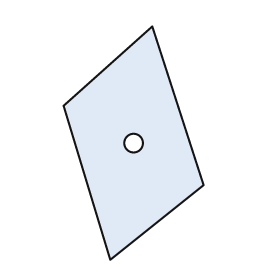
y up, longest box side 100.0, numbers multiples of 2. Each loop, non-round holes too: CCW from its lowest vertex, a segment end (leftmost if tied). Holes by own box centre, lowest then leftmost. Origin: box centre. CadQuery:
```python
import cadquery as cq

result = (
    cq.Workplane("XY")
    .moveTo(-10.0, -50.0)
    .lineTo(30.0, -18.0)
    .lineTo(8.0, 50.0)
    .lineTo(-30.0, 16.0)
    .close()
    .moveTo(0.0, 0.0)
    .circle(4.0)
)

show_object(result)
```